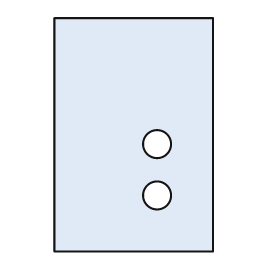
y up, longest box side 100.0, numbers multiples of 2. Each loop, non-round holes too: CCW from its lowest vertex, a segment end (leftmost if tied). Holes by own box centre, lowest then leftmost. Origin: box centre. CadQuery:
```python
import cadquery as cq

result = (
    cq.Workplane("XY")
    .moveTo(-34.0, -50.0)
    .lineTo(34.0, -50.0)
    .lineTo(34.0, 50.0)
    .lineTo(-34.0, 50.0)
    .close()
    .moveTo(10.0, -26.0)
    .circle(6.0)
    .moveTo(10.0, -4.0)
    .circle(6.0)
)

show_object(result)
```